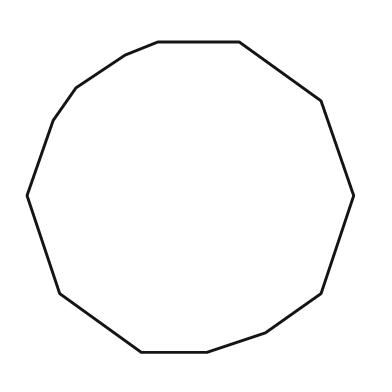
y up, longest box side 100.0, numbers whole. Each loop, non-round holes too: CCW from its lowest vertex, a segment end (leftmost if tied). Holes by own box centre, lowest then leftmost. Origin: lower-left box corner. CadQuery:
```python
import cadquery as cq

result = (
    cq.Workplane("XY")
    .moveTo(35.0, 0.0)
    .lineTo(55.0, 0.0)
    .lineTo(73.0, 6.0)
    .lineTo(90.0, 18.0)
    .lineTo(100.0, 48.0)
    .lineTo(90.0, 77.0)
    .lineTo(65.0, 95.0)
    .lineTo(40.0, 95.0)
    .lineTo(30.0, 91.0)
    .lineTo(15.0, 81.0)
    .lineTo(8.0, 71.0)
    .lineTo(0.0, 48.0)
    .lineTo(10.0, 18.0)
    .close()
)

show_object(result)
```